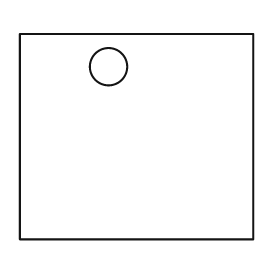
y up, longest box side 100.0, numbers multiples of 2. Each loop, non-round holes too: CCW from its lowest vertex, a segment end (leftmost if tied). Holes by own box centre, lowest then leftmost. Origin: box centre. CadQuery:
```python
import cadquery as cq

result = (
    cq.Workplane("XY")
    .moveTo(-50.0, -44.0)
    .lineTo(50.0, -44.0)
    .lineTo(50.0, 44.0)
    .lineTo(-50.0, 44.0)
    .close()
    .moveTo(-12.0, 30.0)
    .circle(8.0)
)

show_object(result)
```